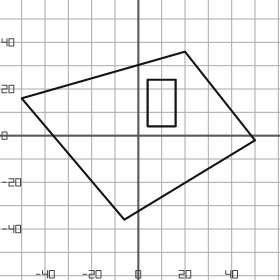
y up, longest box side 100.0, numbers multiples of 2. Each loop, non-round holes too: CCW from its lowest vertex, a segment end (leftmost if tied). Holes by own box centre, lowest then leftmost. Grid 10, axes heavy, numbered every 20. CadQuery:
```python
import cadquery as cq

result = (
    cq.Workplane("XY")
    .moveTo(-6.0, -36.0)
    .lineTo(50.0, -2.0)
    .lineTo(20.0, 36.0)
    .lineTo(-50.0, 16.0)
    .close()
    .moveTo(4.0, 4.0)
    .lineTo(16.0, 4.0)
    .lineTo(16.0, 24.0)
    .lineTo(4.0, 24.0)
    .close()
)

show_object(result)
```